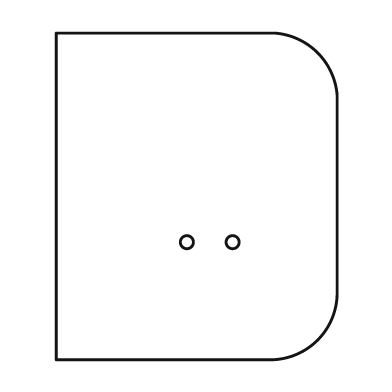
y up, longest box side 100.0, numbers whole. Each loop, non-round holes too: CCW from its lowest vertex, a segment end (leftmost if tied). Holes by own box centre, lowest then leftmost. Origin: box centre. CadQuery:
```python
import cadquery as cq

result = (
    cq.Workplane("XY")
    .moveTo(-43.0, -50.0)
    .lineTo(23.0, -50.0)
    .threePointArc((37.0, -44.0), (43.0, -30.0))
    .lineTo(43.0, 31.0)
    .threePointArc((37.0, 44.0), (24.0, 50.0))
    .lineTo(-43.0, 50.0)
    .close()
    .moveTo(-3.0, -14.0)
    .circle(2.0)
    .moveTo(11.0, -14.0)
    .circle(2.0)
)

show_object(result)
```